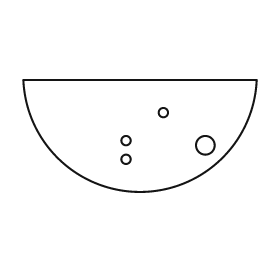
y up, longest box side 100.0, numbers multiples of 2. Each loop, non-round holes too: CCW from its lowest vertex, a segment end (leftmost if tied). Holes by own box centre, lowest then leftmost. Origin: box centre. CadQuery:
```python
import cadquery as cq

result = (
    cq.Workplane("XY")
    .moveTo(-50.0, 24.0)
    .threePointArc((0.0, -24.0), (50.0, 24.0))
    .close()
    .moveTo(-6.0, -10.0)
    .circle(2.0)
    .moveTo(28.0, -4.0)
    .circle(4.0)
    .moveTo(-6.0, -2.0)
    .circle(2.0)
    .moveTo(10.0, 10.0)
    .circle(2.0)
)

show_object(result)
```